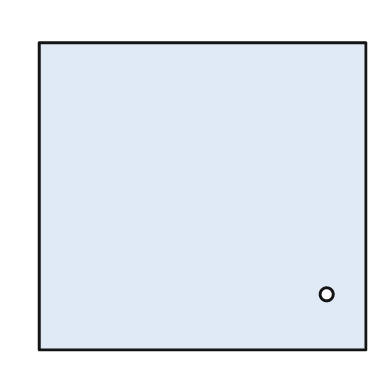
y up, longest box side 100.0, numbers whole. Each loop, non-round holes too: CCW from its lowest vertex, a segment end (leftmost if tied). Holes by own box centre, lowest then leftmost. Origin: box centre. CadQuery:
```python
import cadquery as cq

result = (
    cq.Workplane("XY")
    .moveTo(-50.0, -47.0)
    .lineTo(50.0, -47.0)
    .lineTo(50.0, 47.0)
    .lineTo(-50.0, 47.0)
    .close()
    .moveTo(38.0, -30.0)
    .circle(2.0)
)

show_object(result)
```